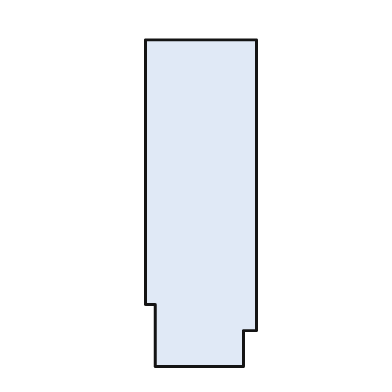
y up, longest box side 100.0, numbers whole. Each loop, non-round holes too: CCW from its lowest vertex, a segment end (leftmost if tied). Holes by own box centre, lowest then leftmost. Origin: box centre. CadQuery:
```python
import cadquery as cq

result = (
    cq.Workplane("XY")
    .moveTo(-14.0, -50.0)
    .lineTo(13.0, -50.0)
    .lineTo(13.0, -39.0)
    .lineTo(17.0, -39.0)
    .lineTo(17.0, 50.0)
    .lineTo(-17.0, 50.0)
    .lineTo(-17.0, -31.0)
    .lineTo(-14.0, -31.0)
    .close()
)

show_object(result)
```